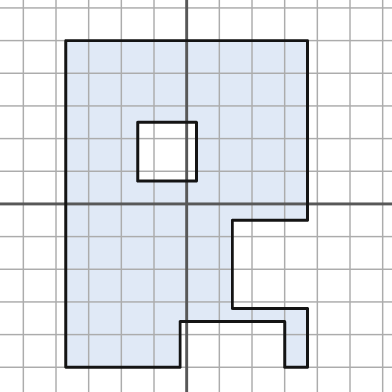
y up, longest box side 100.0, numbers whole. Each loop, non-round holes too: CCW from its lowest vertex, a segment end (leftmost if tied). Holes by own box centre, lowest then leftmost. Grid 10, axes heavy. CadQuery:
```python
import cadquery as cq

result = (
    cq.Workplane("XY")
    .moveTo(-37.0, -50.0)
    .lineTo(-2.0, -50.0)
    .lineTo(-2.0, -36.0)
    .lineTo(30.0, -36.0)
    .lineTo(30.0, -50.0)
    .lineTo(37.0, -50.0)
    .lineTo(37.0, -32.0)
    .lineTo(14.0, -32.0)
    .lineTo(14.0, -5.0)
    .lineTo(37.0, -5.0)
    .lineTo(37.0, 50.0)
    .lineTo(-37.0, 50.0)
    .close()
    .moveTo(-15.0, 7.0)
    .lineTo(3.0, 7.0)
    .lineTo(3.0, 25.0)
    .lineTo(-15.0, 25.0)
    .close()
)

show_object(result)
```